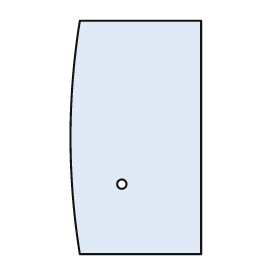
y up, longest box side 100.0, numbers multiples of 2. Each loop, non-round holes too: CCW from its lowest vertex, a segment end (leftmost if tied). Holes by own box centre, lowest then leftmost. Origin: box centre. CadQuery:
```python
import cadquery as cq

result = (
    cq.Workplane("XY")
    .moveTo(-24.0, -50.0)
    .lineTo(28.0, -50.0)
    .lineTo(28.0, 50.0)
    .lineTo(-24.0, 50.0)
    .threePointArc((-28.0, 0.0), (-24.0, -50.0))
    .close()
    .moveTo(-6.0, -20.0)
    .circle(2.0)
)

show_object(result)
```